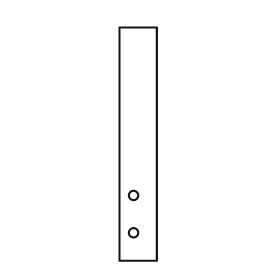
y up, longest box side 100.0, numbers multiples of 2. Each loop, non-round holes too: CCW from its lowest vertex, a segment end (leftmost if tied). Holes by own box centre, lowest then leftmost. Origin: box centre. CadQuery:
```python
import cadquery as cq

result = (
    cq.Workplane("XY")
    .moveTo(-8.0, -50.0)
    .lineTo(8.0, -50.0)
    .lineTo(8.0, 50.0)
    .lineTo(-8.0, 50.0)
    .close()
    .moveTo(-2.0, -38.0)
    .circle(2.0)
    .moveTo(-2.0, -22.0)
    .circle(2.0)
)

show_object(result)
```